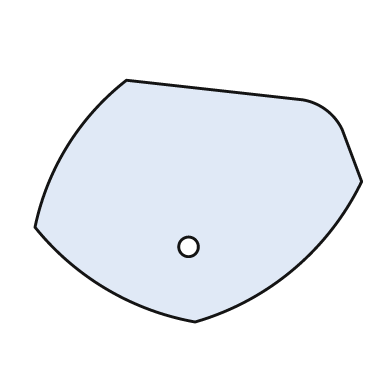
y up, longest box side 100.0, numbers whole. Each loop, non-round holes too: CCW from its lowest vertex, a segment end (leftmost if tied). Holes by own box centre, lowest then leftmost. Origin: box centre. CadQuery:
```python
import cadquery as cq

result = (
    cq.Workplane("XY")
    .moveTo(-1.0, -37.0)
    .threePointArc((29.0, -21.0), (50.0, 6.0))
    .lineTo(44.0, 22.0)
    .threePointArc((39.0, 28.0), (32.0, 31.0))
    .lineTo(-22.0, 37.0)
    .threePointArc((-40.0, 17.0), (-50.0, -8.0))
    .threePointArc((-28.0, -27.0), (-1.0, -37.0))
    .close()
    .moveTo(-3.0, -14.0)
    .circle(3.0)
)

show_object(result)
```